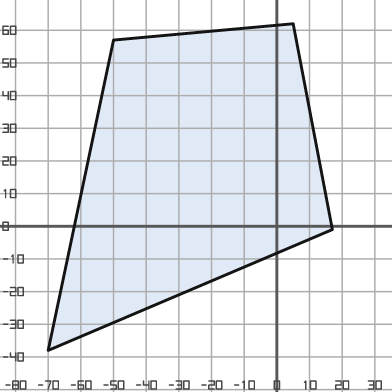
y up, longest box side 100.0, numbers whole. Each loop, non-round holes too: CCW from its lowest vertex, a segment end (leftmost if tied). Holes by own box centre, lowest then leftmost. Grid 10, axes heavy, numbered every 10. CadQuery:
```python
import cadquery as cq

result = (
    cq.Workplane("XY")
    .moveTo(-70.0, -38.0)
    .lineTo(17.0, -1.0)
    .lineTo(5.0, 62.0)
    .lineTo(-50.0, 57.0)
    .close()
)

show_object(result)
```